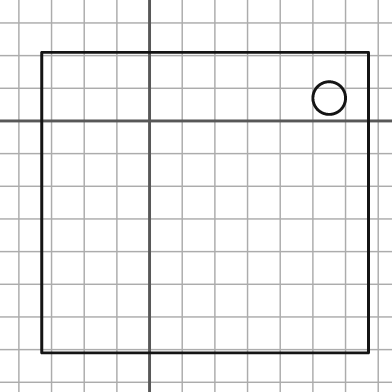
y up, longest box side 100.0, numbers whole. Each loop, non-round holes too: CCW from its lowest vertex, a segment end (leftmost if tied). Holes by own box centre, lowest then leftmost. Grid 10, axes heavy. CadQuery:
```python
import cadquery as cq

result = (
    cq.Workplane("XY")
    .moveTo(-33.0, -71.0)
    .lineTo(67.0, -71.0)
    .lineTo(67.0, 21.0)
    .lineTo(-33.0, 21.0)
    .close()
    .moveTo(55.0, 7.0)
    .circle(5.0)
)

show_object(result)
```